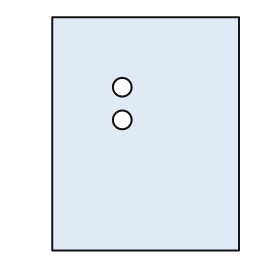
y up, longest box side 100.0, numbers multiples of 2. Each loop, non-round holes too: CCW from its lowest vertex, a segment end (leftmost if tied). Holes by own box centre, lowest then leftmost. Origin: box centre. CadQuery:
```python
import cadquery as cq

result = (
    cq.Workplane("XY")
    .moveTo(-40.0, -50.0)
    .lineTo(40.0, -50.0)
    .lineTo(40.0, 50.0)
    .lineTo(-40.0, 50.0)
    .close()
    .moveTo(-10.0, 6.0)
    .circle(4.0)
    .moveTo(-10.0, 20.0)
    .circle(4.0)
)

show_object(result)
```